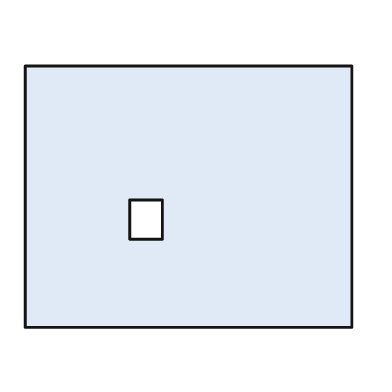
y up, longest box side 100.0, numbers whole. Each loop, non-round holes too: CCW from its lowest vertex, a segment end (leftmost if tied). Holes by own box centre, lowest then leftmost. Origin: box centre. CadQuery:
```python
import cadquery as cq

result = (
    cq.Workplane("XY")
    .moveTo(-50.0, -40.0)
    .lineTo(50.0, -40.0)
    .lineTo(50.0, 40.0)
    .lineTo(-50.0, 40.0)
    .close()
    .moveTo(-18.0, -13.0)
    .lineTo(-8.0, -13.0)
    .lineTo(-8.0, -1.0)
    .lineTo(-18.0, -1.0)
    .close()
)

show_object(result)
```